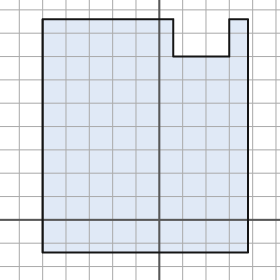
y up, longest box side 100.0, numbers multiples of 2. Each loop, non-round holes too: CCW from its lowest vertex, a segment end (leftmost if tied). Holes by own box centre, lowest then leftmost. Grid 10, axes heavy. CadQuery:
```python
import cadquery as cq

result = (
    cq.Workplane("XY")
    .moveTo(-50.0, -14.0)
    .lineTo(38.0, -14.0)
    .lineTo(38.0, 86.0)
    .lineTo(30.0, 86.0)
    .lineTo(30.0, 70.0)
    .lineTo(6.0, 70.0)
    .lineTo(6.0, 86.0)
    .lineTo(-50.0, 86.0)
    .close()
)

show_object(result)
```